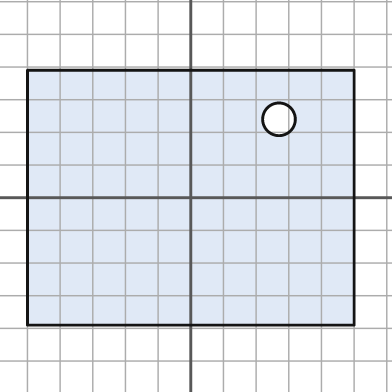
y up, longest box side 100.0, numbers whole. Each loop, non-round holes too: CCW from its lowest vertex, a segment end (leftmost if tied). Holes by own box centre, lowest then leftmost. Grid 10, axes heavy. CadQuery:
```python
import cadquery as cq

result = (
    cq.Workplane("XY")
    .moveTo(-50.0, -39.0)
    .lineTo(50.0, -39.0)
    .lineTo(50.0, 39.0)
    .lineTo(-50.0, 39.0)
    .close()
    .moveTo(27.0, 24.0)
    .circle(5.0)
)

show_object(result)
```